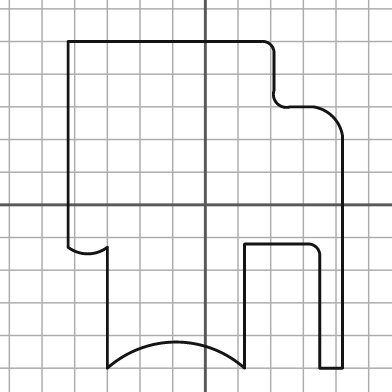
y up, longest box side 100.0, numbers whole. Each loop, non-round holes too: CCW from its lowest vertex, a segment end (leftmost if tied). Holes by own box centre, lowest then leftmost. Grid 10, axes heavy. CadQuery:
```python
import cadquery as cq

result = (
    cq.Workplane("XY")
    .moveTo(-30.0, -50.0)
    .threePointArc((-9.0, -42.0), (12.0, -50.0))
    .lineTo(12.0, -12.0)
    .lineTo(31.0, -12.0)
    .threePointArc((34.0, -13.0), (35.0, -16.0))
    .lineTo(35.0, -50.0)
    .lineTo(42.0, -50.0)
    .lineTo(42.0, 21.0)
    .threePointArc((39.0, 27.0), (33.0, 30.0))
    .lineTo(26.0, 30.0)
    .threePointArc((22.0, 31.0), (21.0, 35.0))
    .lineTo(21.0, 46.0)
    .threePointArc((20.0, 49.0), (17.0, 50.0))
    .lineTo(-42.0, 50.0)
    .lineTo(-42.0, -13.0)
    .threePointArc((-36.0, -15.0), (-30.0, -13.0))
    .close()
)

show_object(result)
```